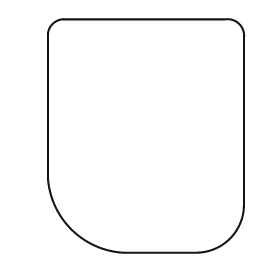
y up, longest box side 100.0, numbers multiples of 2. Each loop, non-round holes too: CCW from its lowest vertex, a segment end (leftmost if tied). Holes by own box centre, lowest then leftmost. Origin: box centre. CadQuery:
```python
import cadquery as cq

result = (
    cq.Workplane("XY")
    .moveTo(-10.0, -50.0)
    .lineTo(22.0, -50.0)
    .threePointArc((36.0, -44.0), (42.0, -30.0))
    .lineTo(42.0, 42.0)
    .threePointArc((40.0, 48.0), (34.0, 50.0))
    .lineTo(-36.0, 50.0)
    .threePointArc((-40.0, 48.0), (-42.0, 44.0))
    .lineTo(-42.0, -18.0)
    .threePointArc((-32.0, -40.0), (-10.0, -50.0))
    .close()
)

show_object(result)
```